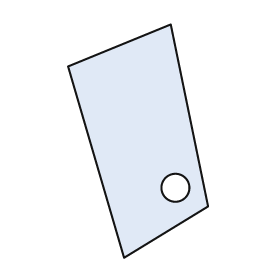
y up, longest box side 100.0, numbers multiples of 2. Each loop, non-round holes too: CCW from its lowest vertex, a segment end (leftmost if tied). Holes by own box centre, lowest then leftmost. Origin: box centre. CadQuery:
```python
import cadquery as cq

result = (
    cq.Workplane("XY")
    .moveTo(-6.0, -50.0)
    .lineTo(30.0, -28.0)
    .lineTo(14.0, 50.0)
    .lineTo(-30.0, 32.0)
    .close()
    .moveTo(16.0, -20.0)
    .circle(6.0)
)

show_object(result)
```